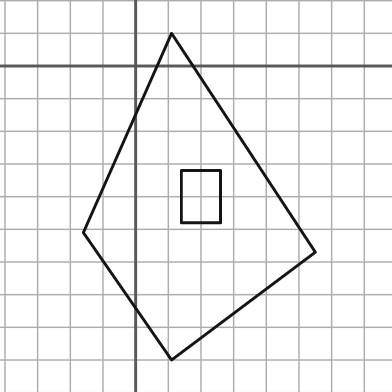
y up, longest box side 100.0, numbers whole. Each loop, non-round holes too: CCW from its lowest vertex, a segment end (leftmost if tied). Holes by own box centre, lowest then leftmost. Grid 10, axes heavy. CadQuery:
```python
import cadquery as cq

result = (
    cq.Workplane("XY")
    .moveTo(11.0, -90.0)
    .lineTo(55.0, -57.0)
    .lineTo(11.0, 10.0)
    .lineTo(-16.0, -51.0)
    .close()
    .moveTo(14.0, -48.0)
    .lineTo(26.0, -48.0)
    .lineTo(26.0, -32.0)
    .lineTo(14.0, -32.0)
    .close()
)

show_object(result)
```